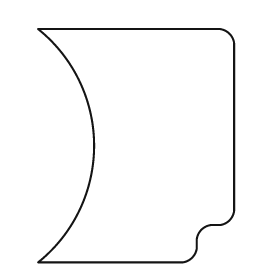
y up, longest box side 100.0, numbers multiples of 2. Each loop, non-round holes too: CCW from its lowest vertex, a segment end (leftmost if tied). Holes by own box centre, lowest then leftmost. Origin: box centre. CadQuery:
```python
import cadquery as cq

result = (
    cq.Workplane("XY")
    .moveTo(-42.0, -50.0)
    .lineTo(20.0, -50.0)
    .threePointArc((24.0, -48.0), (26.0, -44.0))
    .lineTo(26.0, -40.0)
    .threePointArc((28.0, -36.0), (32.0, -34.0))
    .lineTo(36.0, -34.0)
    .threePointArc((40.0, -32.0), (42.0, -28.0))
    .lineTo(42.0, 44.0)
    .threePointArc((40.0, 48.0), (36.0, 50.0))
    .lineTo(-42.0, 50.0)
    .threePointArc((-18.0, 0.0), (-42.0, -50.0))
    .close()
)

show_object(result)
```